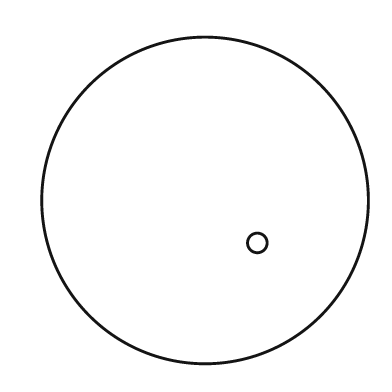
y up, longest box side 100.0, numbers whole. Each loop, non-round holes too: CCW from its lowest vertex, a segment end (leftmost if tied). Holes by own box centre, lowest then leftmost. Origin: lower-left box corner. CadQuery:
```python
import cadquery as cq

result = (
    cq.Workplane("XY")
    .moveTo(50.0, 50.0)
    .circle(50.0)
    .moveTo(66.0, 37.0)
    .circle(3.0)
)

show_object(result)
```